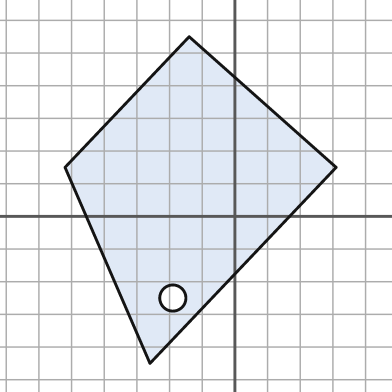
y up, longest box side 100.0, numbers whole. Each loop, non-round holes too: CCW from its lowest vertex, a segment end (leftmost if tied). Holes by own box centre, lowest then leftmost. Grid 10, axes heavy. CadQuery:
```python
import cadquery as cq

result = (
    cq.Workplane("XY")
    .moveTo(-26.0, -45.0)
    .lineTo(31.0, 15.0)
    .lineTo(-14.0, 55.0)
    .lineTo(-52.0, 15.0)
    .close()
    .moveTo(-19.0, -25.0)
    .circle(4.0)
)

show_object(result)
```